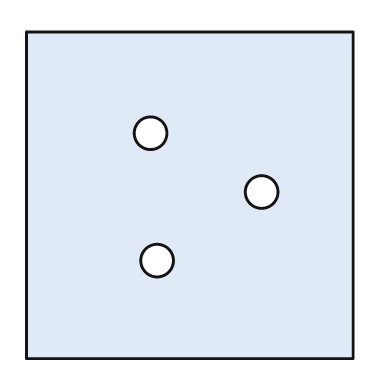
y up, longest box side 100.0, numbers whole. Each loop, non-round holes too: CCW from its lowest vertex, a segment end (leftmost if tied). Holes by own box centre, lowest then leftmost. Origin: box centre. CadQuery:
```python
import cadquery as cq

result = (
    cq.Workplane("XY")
    .moveTo(-50.0, -50.0)
    .lineTo(50.0, -50.0)
    .lineTo(50.0, 50.0)
    .lineTo(-50.0, 50.0)
    .close()
    .moveTo(-10.0, -20.0)
    .circle(5.0)
    .moveTo(22.0, 1.0)
    .circle(5.0)
    .moveTo(-12.0, 19.0)
    .circle(5.0)
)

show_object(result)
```